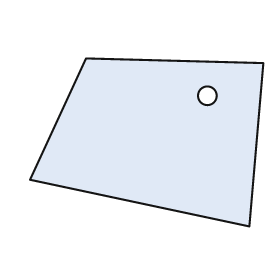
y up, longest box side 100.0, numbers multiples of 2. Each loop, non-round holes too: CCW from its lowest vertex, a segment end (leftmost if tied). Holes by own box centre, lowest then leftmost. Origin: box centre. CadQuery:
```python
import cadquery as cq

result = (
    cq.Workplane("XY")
    .moveTo(44.0, -36.0)
    .lineTo(50.0, 34.0)
    .lineTo(-26.0, 36.0)
    .lineTo(-50.0, -16.0)
    .close()
    .moveTo(26.0, 20.0)
    .circle(4.0)
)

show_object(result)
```